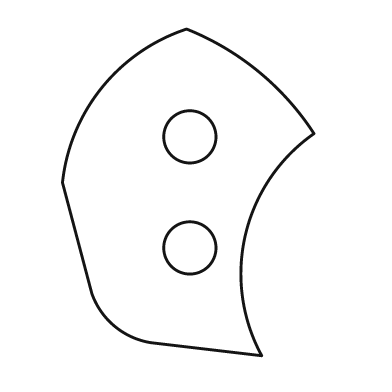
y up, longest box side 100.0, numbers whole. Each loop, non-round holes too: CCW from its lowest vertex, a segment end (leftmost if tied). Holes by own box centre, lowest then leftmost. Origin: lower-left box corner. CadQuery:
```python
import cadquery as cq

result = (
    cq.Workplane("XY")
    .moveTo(61.0, 0.0)
    .threePointArc((56.0, 37.0), (77.0, 68.0))
    .threePointArc((60.0, 87.0), (38.0, 100.0))
    .threePointArc((12.0, 82.0), (0.0, 53.0))
    .lineTo(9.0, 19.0)
    .threePointArc((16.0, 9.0), (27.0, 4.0))
    .close()
    .moveTo(39.0, 33.0)
    .circle(8.0)
    .moveTo(39.0, 67.0)
    .circle(8.0)
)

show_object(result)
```